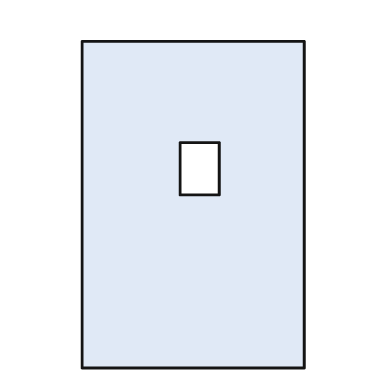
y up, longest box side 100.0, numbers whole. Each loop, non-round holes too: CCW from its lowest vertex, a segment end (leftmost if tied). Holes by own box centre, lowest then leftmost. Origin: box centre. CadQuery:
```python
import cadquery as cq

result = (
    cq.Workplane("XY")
    .moveTo(-34.0, -50.0)
    .lineTo(34.0, -50.0)
    .lineTo(34.0, 50.0)
    .lineTo(-34.0, 50.0)
    .close()
    .moveTo(-4.0, 3.0)
    .lineTo(8.0, 3.0)
    .lineTo(8.0, 19.0)
    .lineTo(-4.0, 19.0)
    .close()
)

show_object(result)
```